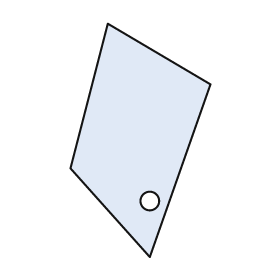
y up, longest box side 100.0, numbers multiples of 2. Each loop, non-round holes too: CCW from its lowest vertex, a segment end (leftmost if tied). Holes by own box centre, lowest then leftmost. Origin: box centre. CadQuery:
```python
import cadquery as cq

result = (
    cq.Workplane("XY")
    .moveTo(4.0, -50.0)
    .lineTo(30.0, 24.0)
    .lineTo(-14.0, 50.0)
    .lineTo(-30.0, -12.0)
    .close()
    .moveTo(4.0, -26.0)
    .circle(4.0)
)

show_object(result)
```